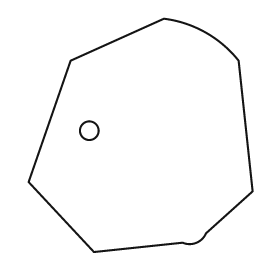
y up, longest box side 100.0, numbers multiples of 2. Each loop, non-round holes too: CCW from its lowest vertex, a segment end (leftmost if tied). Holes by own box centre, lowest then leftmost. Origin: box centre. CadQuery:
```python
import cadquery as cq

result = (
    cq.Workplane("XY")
    .moveTo(-20.0, -50.0)
    .lineTo(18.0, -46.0)
    .threePointArc((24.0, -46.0), (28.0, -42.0))
    .lineTo(48.0, -24.0)
    .lineTo(42.0, 32.0)
    .threePointArc((28.0, 44.0), (10.0, 50.0))
    .lineTo(-30.0, 32.0)
    .lineTo(-48.0, -20.0)
    .close()
    .moveTo(-22.0, 2.0)
    .circle(4.0)
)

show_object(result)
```